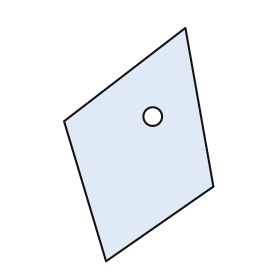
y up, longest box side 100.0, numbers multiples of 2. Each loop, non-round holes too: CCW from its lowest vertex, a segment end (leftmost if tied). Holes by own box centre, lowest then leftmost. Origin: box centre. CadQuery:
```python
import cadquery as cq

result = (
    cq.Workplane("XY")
    .moveTo(-14.0, -50.0)
    .lineTo(32.0, -18.0)
    .lineTo(20.0, 50.0)
    .lineTo(-32.0, 10.0)
    .close()
    .moveTo(6.0, 12.0)
    .circle(4.0)
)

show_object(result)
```